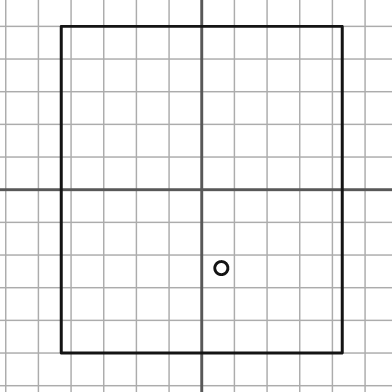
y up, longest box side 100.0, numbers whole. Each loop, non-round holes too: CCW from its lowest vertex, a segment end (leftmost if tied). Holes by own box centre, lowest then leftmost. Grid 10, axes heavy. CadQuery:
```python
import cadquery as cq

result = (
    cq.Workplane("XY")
    .moveTo(-43.0, -50.0)
    .lineTo(43.0, -50.0)
    .lineTo(43.0, 50.0)
    .lineTo(-43.0, 50.0)
    .close()
    .moveTo(6.0, -24.0)
    .circle(2.0)
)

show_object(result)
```